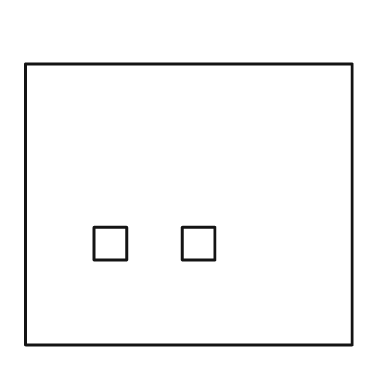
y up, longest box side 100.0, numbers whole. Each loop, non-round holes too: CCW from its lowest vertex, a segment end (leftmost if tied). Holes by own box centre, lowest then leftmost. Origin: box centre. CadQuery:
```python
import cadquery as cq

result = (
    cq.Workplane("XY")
    .moveTo(-50.0, -43.0)
    .lineTo(50.0, -43.0)
    .lineTo(50.0, 43.0)
    .lineTo(-50.0, 43.0)
    .close()
    .moveTo(-29.0, -17.0)
    .lineTo(-19.0, -17.0)
    .lineTo(-19.0, -7.0)
    .lineTo(-29.0, -7.0)
    .close()
    .moveTo(-2.0, -17.0)
    .lineTo(8.0, -17.0)
    .lineTo(8.0, -7.0)
    .lineTo(-2.0, -7.0)
    .close()
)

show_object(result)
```